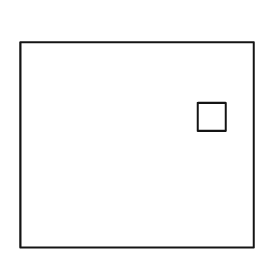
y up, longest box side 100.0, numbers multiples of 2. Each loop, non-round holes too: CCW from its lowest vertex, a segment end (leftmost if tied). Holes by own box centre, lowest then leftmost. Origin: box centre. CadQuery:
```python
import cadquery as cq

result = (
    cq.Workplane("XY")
    .moveTo(-50.0, -44.0)
    .lineTo(50.0, -44.0)
    .lineTo(50.0, 44.0)
    .lineTo(-50.0, 44.0)
    .close()
    .moveTo(26.0, 6.0)
    .lineTo(38.0, 6.0)
    .lineTo(38.0, 18.0)
    .lineTo(26.0, 18.0)
    .close()
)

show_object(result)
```